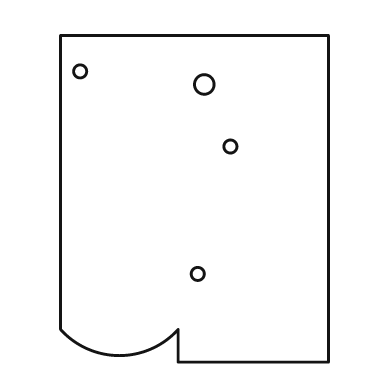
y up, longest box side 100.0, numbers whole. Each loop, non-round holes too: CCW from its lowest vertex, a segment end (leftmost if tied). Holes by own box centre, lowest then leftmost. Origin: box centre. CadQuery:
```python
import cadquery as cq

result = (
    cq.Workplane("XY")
    .moveTo(-5.0, -50.0)
    .lineTo(41.0, -50.0)
    .lineTo(41.0, 50.0)
    .lineTo(-41.0, 50.0)
    .lineTo(-41.0, -40.0)
    .threePointArc((-23.0, -48.0), (-5.0, -40.0))
    .close()
    .moveTo(1.0, -23.0)
    .circle(2.0)
    .moveTo(11.0, 16.0)
    .circle(2.0)
    .moveTo(3.0, 35.0)
    .circle(3.0)
    .moveTo(-35.0, 39.0)
    .circle(2.0)
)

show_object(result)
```